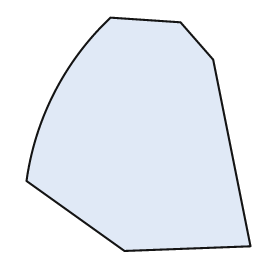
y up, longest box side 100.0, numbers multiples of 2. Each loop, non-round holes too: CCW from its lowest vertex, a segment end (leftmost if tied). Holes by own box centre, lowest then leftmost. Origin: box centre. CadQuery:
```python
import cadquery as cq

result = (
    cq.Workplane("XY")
    .moveTo(-6.0, -50.0)
    .lineTo(48.0, -48.0)
    .lineTo(32.0, 32.0)
    .lineTo(18.0, 48.0)
    .lineTo(-12.0, 50.0)
    .threePointArc((-36.0, 18.0), (-48.0, -20.0))
    .close()
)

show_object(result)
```